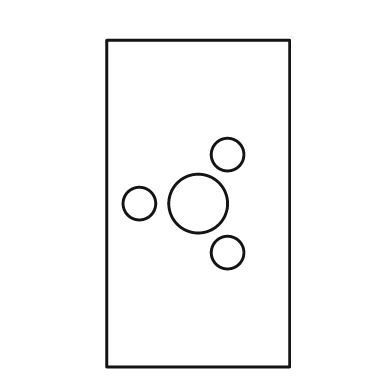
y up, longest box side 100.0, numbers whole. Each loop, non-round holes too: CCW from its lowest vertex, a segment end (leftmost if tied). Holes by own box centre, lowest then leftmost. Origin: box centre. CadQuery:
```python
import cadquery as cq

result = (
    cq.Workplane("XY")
    .moveTo(-28.0, -50.0)
    .lineTo(28.0, -50.0)
    .lineTo(28.0, 50.0)
    .lineTo(-28.0, 50.0)
    .close()
    .moveTo(9.0, -15.0)
    .circle(5.0)
    .moveTo(-18.0, 0.0)
    .circle(5.0)
    .moveTo(0.0, 0.0)
    .circle(9.0)
    .moveTo(9.0, 15.0)
    .circle(5.0)
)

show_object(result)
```